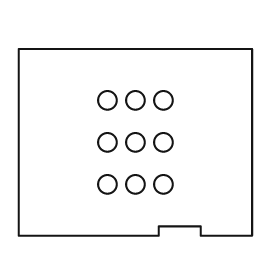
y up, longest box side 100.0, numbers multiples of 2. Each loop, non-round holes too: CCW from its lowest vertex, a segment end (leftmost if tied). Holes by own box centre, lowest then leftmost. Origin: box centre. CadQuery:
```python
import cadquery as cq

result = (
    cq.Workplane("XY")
    .moveTo(-50.0, -40.0)
    .lineTo(10.0, -40.0)
    .lineTo(10.0, -36.0)
    .lineTo(28.0, -36.0)
    .lineTo(28.0, -40.0)
    .lineTo(50.0, -40.0)
    .lineTo(50.0, 40.0)
    .lineTo(-50.0, 40.0)
    .close()
    .moveTo(-12.0, -18.0)
    .circle(4.0)
    .moveTo(0.0, -18.0)
    .circle(4.0)
    .moveTo(12.0, -18.0)
    .circle(4.0)
    .moveTo(-12.0, 0.0)
    .circle(4.0)
    .moveTo(0.0, 0.0)
    .circle(4.0)
    .moveTo(12.0, 0.0)
    .circle(4.0)
    .moveTo(-12.0, 18.0)
    .circle(4.0)
    .moveTo(0.0, 18.0)
    .circle(4.0)
    .moveTo(12.0, 18.0)
    .circle(4.0)
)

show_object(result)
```